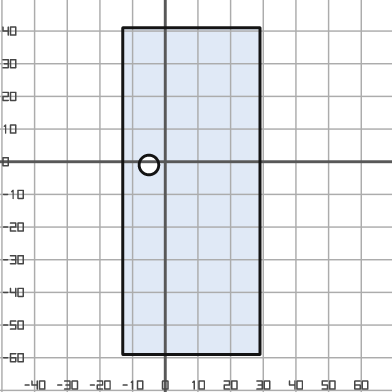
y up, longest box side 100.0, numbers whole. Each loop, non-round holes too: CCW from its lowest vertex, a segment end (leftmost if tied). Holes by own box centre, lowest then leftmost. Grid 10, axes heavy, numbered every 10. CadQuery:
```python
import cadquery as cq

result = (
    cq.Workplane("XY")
    .moveTo(-13.0, -59.0)
    .lineTo(29.0, -59.0)
    .lineTo(29.0, 41.0)
    .lineTo(-13.0, 41.0)
    .close()
    .moveTo(-5.0, -1.0)
    .circle(3.0)
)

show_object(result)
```